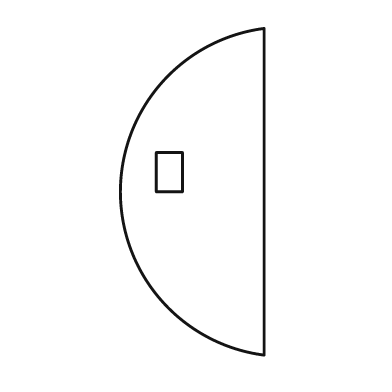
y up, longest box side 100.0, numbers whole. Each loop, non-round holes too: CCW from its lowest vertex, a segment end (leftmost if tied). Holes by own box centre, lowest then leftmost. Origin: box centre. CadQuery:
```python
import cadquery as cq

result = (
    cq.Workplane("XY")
    .moveTo(22.0, -50.0)
    .lineTo(22.0, 50.0)
    .threePointArc((-22.0, 0.0), (22.0, -50.0))
    .close()
    .moveTo(-11.0, 0.0)
    .lineTo(-3.0, 0.0)
    .lineTo(-3.0, 12.0)
    .lineTo(-11.0, 12.0)
    .close()
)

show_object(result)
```